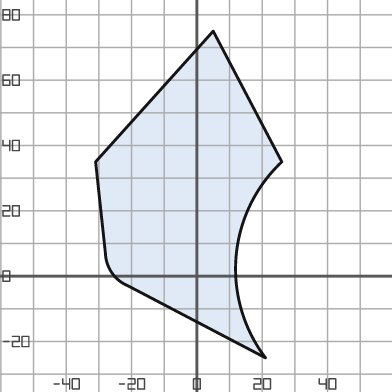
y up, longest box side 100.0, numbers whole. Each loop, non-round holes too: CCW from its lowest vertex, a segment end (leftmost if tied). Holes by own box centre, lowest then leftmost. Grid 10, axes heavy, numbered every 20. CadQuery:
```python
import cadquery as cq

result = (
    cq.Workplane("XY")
    .moveTo(21.0, -25.0)
    .threePointArc((12.0, 6.0), (26.0, 35.0))
    .lineTo(5.0, 75.0)
    .lineTo(-31.0, 35.0)
    .lineTo(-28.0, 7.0)
    .threePointArc((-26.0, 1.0), (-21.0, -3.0))
    .close()
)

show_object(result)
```